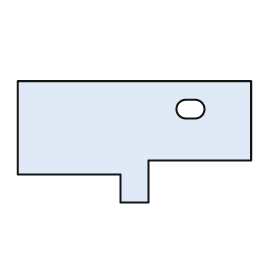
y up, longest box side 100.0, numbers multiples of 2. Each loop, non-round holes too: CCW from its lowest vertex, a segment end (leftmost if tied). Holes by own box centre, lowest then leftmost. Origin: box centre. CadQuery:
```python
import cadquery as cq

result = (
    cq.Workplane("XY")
    .moveTo(-6.0, -26.0)
    .lineTo(6.0, -26.0)
    .lineTo(6.0, -8.0)
    .lineTo(50.0, -8.0)
    .lineTo(50.0, 26.0)
    .lineTo(-50.0, 26.0)
    .lineTo(-50.0, -14.0)
    .lineTo(-6.0, -14.0)
    .close()
    .moveTo(22.0, 10.0)
    .lineTo(26.0, 10.0)
    .threePointArc((30.0, 14.0), (26.0, 18.0))
    .lineTo(22.0, 18.0)
    .threePointArc((18.0, 14.0), (22.0, 10.0))
    .close()
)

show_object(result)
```